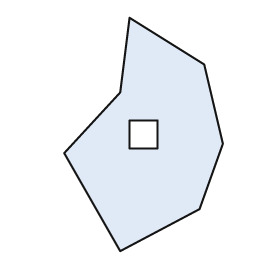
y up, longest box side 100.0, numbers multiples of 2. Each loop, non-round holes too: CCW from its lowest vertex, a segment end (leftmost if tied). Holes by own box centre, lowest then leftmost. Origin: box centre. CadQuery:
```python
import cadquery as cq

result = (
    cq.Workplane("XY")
    .moveTo(-10.0, -50.0)
    .lineTo(24.0, -32.0)
    .lineTo(34.0, -4.0)
    .lineTo(26.0, 30.0)
    .lineTo(-6.0, 50.0)
    .lineTo(-10.0, 18.0)
    .lineTo(-34.0, -8.0)
    .close()
    .moveTo(-6.0, -6.0)
    .lineTo(6.0, -6.0)
    .lineTo(6.0, 6.0)
    .lineTo(-6.0, 6.0)
    .close()
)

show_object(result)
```